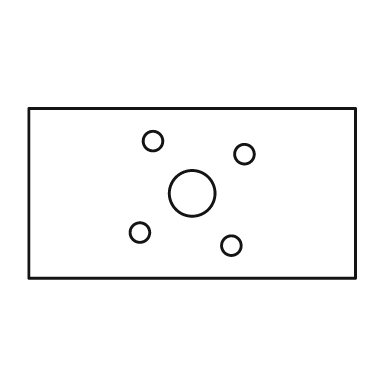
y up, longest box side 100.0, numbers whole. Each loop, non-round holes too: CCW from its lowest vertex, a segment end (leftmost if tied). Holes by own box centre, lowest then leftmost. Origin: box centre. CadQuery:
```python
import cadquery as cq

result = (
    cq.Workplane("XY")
    .moveTo(-50.0, -26.0)
    .lineTo(50.0, -26.0)
    .lineTo(50.0, 26.0)
    .lineTo(-50.0, 26.0)
    .close()
    .moveTo(12.0, -16.0)
    .circle(3.0)
    .moveTo(-16.0, -12.0)
    .circle(3.0)
    .moveTo(0.0, 0.0)
    .circle(7.0)
    .moveTo(16.0, 12.0)
    .circle(3.0)
    .moveTo(-12.0, 16.0)
    .circle(3.0)
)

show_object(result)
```